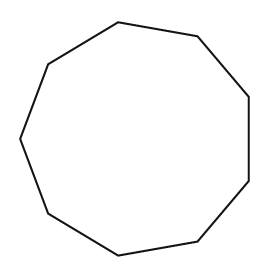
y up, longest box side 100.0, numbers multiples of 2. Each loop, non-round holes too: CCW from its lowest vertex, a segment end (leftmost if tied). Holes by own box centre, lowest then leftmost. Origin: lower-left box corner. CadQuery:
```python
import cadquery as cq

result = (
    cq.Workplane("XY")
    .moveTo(42.0, 0.0)
    .lineTo(76.0, 6.0)
    .lineTo(98.0, 32.0)
    .lineTo(98.0, 68.0)
    .lineTo(76.0, 94.0)
    .lineTo(42.0, 100.0)
    .lineTo(12.0, 82.0)
    .lineTo(0.0, 50.0)
    .lineTo(12.0, 18.0)
    .close()
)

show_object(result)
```